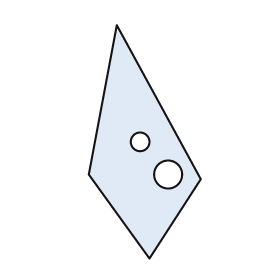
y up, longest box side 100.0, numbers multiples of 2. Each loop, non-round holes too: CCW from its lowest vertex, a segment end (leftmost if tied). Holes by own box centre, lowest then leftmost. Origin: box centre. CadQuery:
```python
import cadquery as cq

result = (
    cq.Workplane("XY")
    .moveTo(2.0, -50.0)
    .lineTo(24.0, -16.0)
    .lineTo(-12.0, 50.0)
    .lineTo(-24.0, -14.0)
    .close()
    .moveTo(10.0, -14.0)
    .circle(6.0)
    .moveTo(-2.0, 0.0)
    .circle(4.0)
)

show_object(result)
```